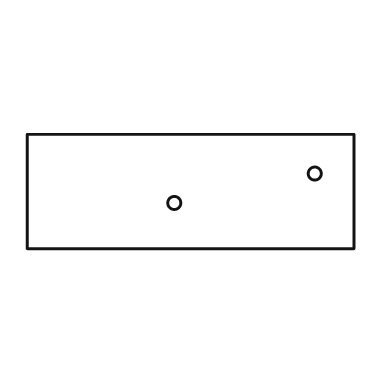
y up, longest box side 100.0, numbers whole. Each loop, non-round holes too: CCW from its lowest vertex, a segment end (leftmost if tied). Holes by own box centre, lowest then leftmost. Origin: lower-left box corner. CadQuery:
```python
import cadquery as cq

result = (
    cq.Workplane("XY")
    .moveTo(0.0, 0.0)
    .lineTo(100.0, 0.0)
    .lineTo(100.0, 35.0)
    .lineTo(0.0, 35.0)
    .close()
    .moveTo(45.0, 14.0)
    .circle(2.0)
    .moveTo(88.0, 23.0)
    .circle(2.0)
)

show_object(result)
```